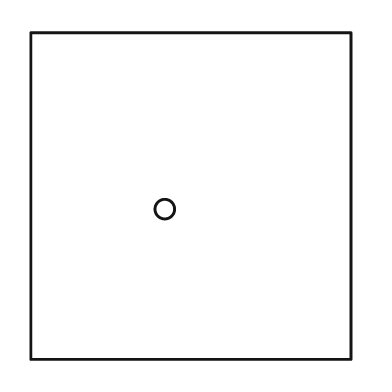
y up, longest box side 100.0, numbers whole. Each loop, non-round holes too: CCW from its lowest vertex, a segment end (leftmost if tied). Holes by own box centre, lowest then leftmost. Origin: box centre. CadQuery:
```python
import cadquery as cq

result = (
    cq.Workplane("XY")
    .moveTo(-49.0, -50.0)
    .lineTo(49.0, -50.0)
    .lineTo(49.0, 50.0)
    .lineTo(-49.0, 50.0)
    .close()
    .moveTo(-8.0, -4.0)
    .circle(3.0)
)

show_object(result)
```